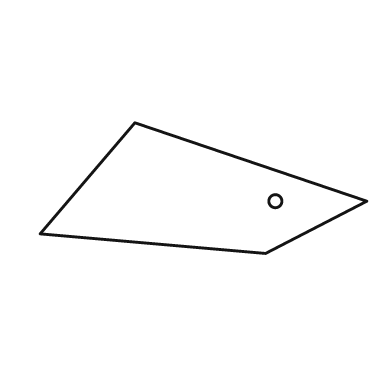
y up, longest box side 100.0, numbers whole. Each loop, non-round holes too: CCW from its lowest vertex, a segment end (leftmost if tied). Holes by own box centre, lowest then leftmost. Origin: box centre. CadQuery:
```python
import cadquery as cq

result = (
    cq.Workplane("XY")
    .moveTo(19.0, -20.0)
    .lineTo(50.0, -4.0)
    .lineTo(-21.0, 20.0)
    .lineTo(-50.0, -14.0)
    .close()
    .moveTo(22.0, -4.0)
    .circle(2.0)
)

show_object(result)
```